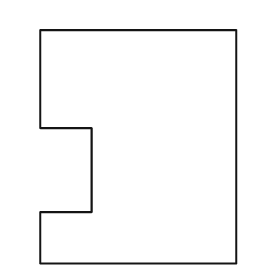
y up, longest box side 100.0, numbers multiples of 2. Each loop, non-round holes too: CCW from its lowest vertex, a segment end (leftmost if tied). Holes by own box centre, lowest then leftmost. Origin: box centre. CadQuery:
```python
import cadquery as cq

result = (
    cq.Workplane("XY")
    .moveTo(-42.0, -50.0)
    .lineTo(42.0, -50.0)
    .lineTo(42.0, 50.0)
    .lineTo(-42.0, 50.0)
    .lineTo(-42.0, 8.0)
    .lineTo(-20.0, 8.0)
    .lineTo(-20.0, -28.0)
    .lineTo(-42.0, -28.0)
    .close()
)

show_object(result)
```